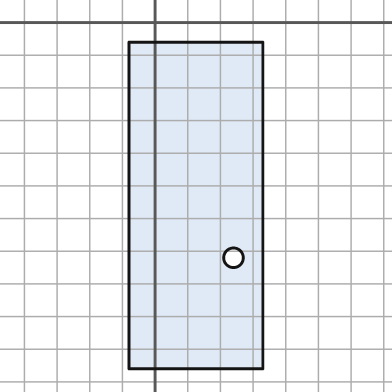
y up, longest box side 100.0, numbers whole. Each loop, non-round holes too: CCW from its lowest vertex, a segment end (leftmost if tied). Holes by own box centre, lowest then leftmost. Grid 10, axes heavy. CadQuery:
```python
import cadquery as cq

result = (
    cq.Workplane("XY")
    .moveTo(-8.0, -106.0)
    .lineTo(33.0, -106.0)
    .lineTo(33.0, -6.0)
    .lineTo(-8.0, -6.0)
    .close()
    .moveTo(24.0, -72.0)
    .circle(3.0)
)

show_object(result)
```